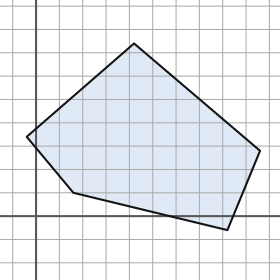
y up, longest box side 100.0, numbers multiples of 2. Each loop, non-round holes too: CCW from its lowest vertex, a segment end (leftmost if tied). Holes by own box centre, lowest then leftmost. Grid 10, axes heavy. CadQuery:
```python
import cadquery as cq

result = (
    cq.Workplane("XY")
    .moveTo(82.0, -6.0)
    .lineTo(96.0, 28.0)
    .lineTo(42.0, 74.0)
    .lineTo(-4.0, 34.0)
    .lineTo(16.0, 10.0)
    .close()
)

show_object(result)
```